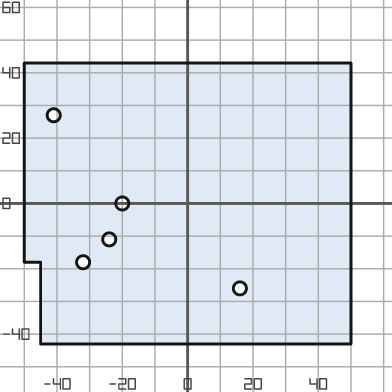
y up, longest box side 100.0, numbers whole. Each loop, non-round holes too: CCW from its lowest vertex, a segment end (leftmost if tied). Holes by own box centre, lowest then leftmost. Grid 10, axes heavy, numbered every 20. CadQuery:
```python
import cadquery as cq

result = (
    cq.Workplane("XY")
    .moveTo(-45.0, -43.0)
    .lineTo(50.0, -43.0)
    .lineTo(50.0, 43.0)
    .lineTo(-50.0, 43.0)
    .lineTo(-50.0, -18.0)
    .lineTo(-45.0, -18.0)
    .close()
    .moveTo(16.0, -26.0)
    .circle(2.0)
    .moveTo(-32.0, -18.0)
    .circle(2.0)
    .moveTo(-24.0, -11.0)
    .circle(2.0)
    .moveTo(-20.0, 0.0)
    .circle(2.0)
    .moveTo(-41.0, 27.0)
    .circle(2.0)
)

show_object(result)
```